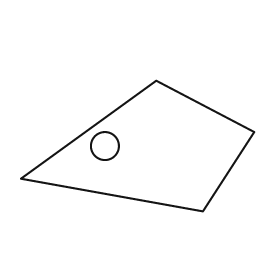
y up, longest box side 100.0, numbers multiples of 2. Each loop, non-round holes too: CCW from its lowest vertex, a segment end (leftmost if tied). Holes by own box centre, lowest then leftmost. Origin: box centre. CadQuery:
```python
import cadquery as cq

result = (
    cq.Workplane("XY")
    .moveTo(28.0, -28.0)
    .lineTo(50.0, 6.0)
    .lineTo(8.0, 28.0)
    .lineTo(-50.0, -14.0)
    .close()
    .moveTo(-14.0, 0.0)
    .circle(6.0)
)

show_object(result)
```